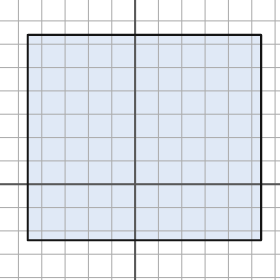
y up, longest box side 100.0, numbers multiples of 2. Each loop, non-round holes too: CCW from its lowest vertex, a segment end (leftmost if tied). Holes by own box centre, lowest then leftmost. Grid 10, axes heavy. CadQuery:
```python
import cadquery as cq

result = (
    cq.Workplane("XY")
    .moveTo(-46.0, -24.0)
    .lineTo(54.0, -24.0)
    .lineTo(54.0, 64.0)
    .lineTo(-46.0, 64.0)
    .close()
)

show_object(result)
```